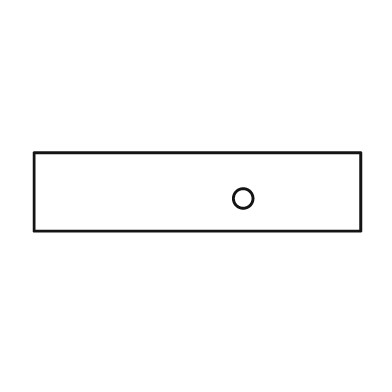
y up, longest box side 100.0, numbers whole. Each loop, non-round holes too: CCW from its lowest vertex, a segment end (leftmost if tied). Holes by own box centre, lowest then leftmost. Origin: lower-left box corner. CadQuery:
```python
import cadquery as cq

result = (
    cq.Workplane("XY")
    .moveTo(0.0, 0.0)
    .lineTo(100.0, 0.0)
    .lineTo(100.0, 24.0)
    .lineTo(0.0, 24.0)
    .close()
    .moveTo(64.0, 10.0)
    .circle(3.0)
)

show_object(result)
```